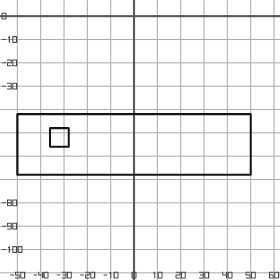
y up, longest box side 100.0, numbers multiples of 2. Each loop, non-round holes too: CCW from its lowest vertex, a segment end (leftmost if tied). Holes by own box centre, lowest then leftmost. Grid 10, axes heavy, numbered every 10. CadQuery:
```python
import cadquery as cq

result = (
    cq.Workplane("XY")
    .moveTo(-50.0, -68.0)
    .lineTo(50.0, -68.0)
    .lineTo(50.0, -42.0)
    .lineTo(-50.0, -42.0)
    .close()
    .moveTo(-36.0, -56.0)
    .lineTo(-28.0, -56.0)
    .lineTo(-28.0, -48.0)
    .lineTo(-36.0, -48.0)
    .close()
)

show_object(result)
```